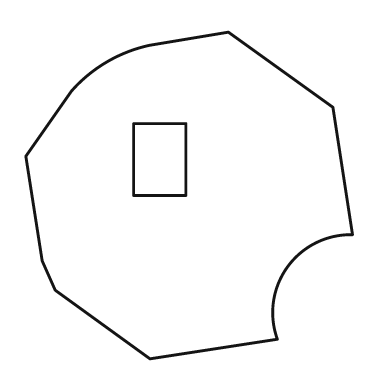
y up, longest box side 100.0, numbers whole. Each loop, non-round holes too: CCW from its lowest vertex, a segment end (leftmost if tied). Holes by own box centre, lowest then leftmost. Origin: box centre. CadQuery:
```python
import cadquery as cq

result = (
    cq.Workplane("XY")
    .moveTo(-12.0, -50.0)
    .lineTo(27.0, -44.0)
    .threePointArc((30.0, -22.0), (50.0, -12.0))
    .lineTo(44.0, 27.0)
    .lineTo(12.0, 50.0)
    .lineTo(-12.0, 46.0)
    .threePointArc((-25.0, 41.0), (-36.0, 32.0))
    .lineTo(-50.0, 12.0)
    .lineTo(-45.0, -20.0)
    .lineTo(-41.0, -29.0)
    .close()
    .moveTo(-17.0, 0.0)
    .lineTo(-1.0, 0.0)
    .lineTo(-1.0, 22.0)
    .lineTo(-17.0, 22.0)
    .close()
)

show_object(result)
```